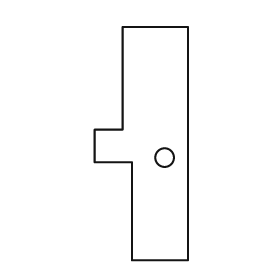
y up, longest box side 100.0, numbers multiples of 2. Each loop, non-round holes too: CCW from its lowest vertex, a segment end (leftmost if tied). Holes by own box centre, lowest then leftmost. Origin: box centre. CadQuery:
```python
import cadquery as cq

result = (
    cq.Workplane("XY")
    .moveTo(-4.0, -50.0)
    .lineTo(20.0, -50.0)
    .lineTo(20.0, 50.0)
    .lineTo(-8.0, 50.0)
    .lineTo(-8.0, 6.0)
    .lineTo(-20.0, 6.0)
    .lineTo(-20.0, -8.0)
    .lineTo(-4.0, -8.0)
    .close()
    .moveTo(10.0, -6.0)
    .circle(4.0)
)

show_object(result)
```